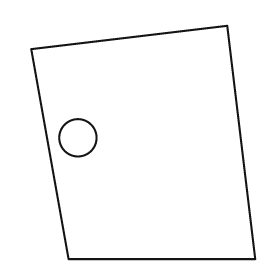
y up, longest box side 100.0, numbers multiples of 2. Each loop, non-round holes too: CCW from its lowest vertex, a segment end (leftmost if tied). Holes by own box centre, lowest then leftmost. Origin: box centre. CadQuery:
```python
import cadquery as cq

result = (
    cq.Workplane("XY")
    .moveTo(-32.0, -50.0)
    .lineTo(48.0, -50.0)
    .lineTo(36.0, 50.0)
    .lineTo(-48.0, 40.0)
    .close()
    .moveTo(-28.0, 2.0)
    .circle(8.0)
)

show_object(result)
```